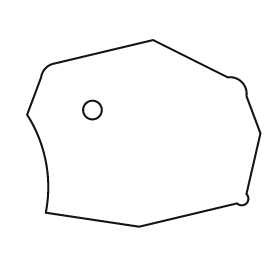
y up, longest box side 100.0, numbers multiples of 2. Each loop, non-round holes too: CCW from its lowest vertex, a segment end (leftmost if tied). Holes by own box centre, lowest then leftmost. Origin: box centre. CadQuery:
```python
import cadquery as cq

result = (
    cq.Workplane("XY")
    .moveTo(-2.0, -40.0)
    .lineTo(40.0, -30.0)
    .threePointArc((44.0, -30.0), (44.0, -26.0))
    .lineTo(50.0, 0.0)
    .lineTo(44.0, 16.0)
    .threePointArc((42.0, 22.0), (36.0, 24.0))
    .lineTo(4.0, 40.0)
    .lineTo(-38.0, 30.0)
    .threePointArc((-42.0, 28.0), (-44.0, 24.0))
    .lineTo(-50.0, 8.0)
    .threePointArc((-42.0, -12.0), (-42.0, -34.0))
    .close()
    .moveTo(-22.0, 10.0)
    .circle(4.0)
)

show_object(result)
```